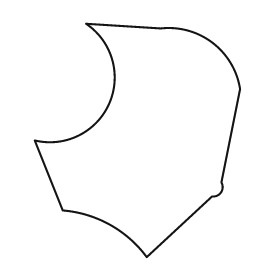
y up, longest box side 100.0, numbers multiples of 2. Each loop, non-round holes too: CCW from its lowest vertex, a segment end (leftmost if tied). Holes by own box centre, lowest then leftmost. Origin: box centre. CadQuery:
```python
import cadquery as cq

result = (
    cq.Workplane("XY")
    .moveTo(4.0, -50.0)
    .lineTo(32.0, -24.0)
    .threePointArc((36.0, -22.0), (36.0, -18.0))
    .lineTo(44.0, 22.0)
    .threePointArc((32.0, 42.0), (10.0, 48.0))
    .lineTo(-22.0, 50.0)
    .threePointArc((-12.0, 16.0), (-44.0, 0.0))
    .lineTo(-32.0, -30.0)
    .threePointArc((-12.0, -36.0), (4.0, -50.0))
    .close()
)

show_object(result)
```